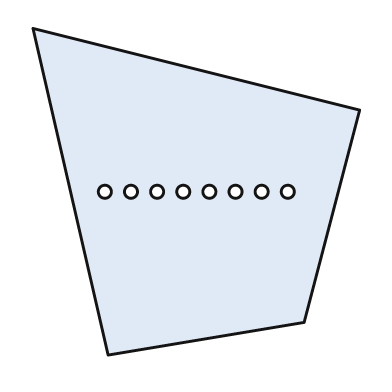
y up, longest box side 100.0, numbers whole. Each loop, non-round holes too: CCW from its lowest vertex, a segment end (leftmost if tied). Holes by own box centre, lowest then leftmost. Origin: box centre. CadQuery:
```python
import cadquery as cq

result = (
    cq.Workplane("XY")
    .moveTo(-27.0, -50.0)
    .lineTo(33.0, -40.0)
    .lineTo(50.0, 25.0)
    .lineTo(-50.0, 50.0)
    .close()
    .moveTo(-28.0, 0.0)
    .circle(2.0)
    .moveTo(-20.0, 0.0)
    .circle(2.0)
    .moveTo(-12.0, 0.0)
    .circle(2.0)
    .moveTo(-4.0, 0.0)
    .circle(2.0)
    .moveTo(4.0, 0.0)
    .circle(2.0)
    .moveTo(12.0, 0.0)
    .circle(2.0)
    .moveTo(20.0, 0.0)
    .circle(2.0)
    .moveTo(28.0, 0.0)
    .circle(2.0)
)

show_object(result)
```